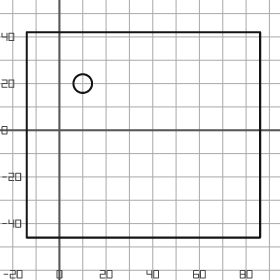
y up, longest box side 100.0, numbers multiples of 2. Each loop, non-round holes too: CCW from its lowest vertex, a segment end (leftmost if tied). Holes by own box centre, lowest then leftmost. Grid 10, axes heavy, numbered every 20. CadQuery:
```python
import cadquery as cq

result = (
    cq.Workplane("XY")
    .moveTo(-14.0, -46.0)
    .lineTo(86.0, -46.0)
    .lineTo(86.0, 42.0)
    .lineTo(-14.0, 42.0)
    .close()
    .moveTo(10.0, 20.0)
    .circle(4.0)
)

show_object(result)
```